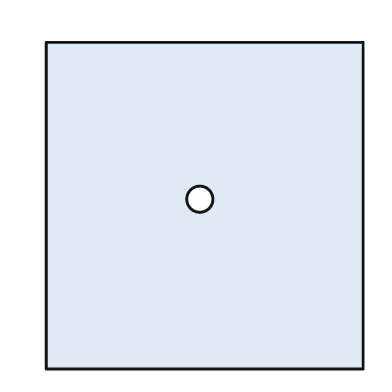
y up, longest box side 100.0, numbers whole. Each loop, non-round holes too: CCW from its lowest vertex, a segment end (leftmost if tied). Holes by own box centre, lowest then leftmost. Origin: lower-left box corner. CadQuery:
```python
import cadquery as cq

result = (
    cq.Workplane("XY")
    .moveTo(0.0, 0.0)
    .lineTo(97.0, 0.0)
    .lineTo(97.0, 100.0)
    .lineTo(0.0, 100.0)
    .close()
    .moveTo(47.0, 52.0)
    .circle(4.0)
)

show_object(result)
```